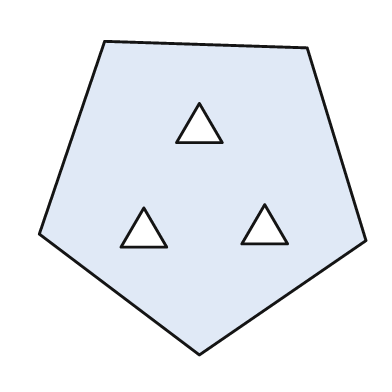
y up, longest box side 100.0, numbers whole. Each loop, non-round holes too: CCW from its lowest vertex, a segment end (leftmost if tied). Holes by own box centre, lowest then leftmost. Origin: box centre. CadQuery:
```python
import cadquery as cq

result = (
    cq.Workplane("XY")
    .moveTo(-1.0, -48.0)
    .lineTo(50.0, -13.0)
    .lineTo(32.0, 46.0)
    .lineTo(-30.0, 48.0)
    .lineTo(-50.0, -11.0)
    .close()
    .moveTo(-25.0, -15.0)
    .lineTo(-11.0, -15.0)
    .lineTo(-18.0, -3.0)
    .close()
    .moveTo(12.0, -14.0)
    .lineTo(26.0, -14.0)
    .lineTo(19.0, -2.0)
    .close()
    .moveTo(-8.0, 17.0)
    .lineTo(6.0, 17.0)
    .lineTo(-1.0, 29.0)
    .close()
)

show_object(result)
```